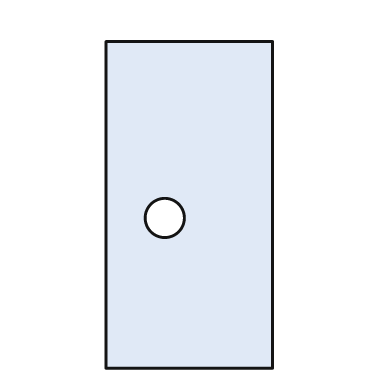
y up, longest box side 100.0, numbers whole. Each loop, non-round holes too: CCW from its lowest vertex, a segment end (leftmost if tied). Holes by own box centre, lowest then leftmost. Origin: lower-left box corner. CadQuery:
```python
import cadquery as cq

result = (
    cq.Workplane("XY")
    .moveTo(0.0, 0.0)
    .lineTo(51.0, 0.0)
    .lineTo(51.0, 100.0)
    .lineTo(0.0, 100.0)
    .close()
    .moveTo(18.0, 46.0)
    .circle(6.0)
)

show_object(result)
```